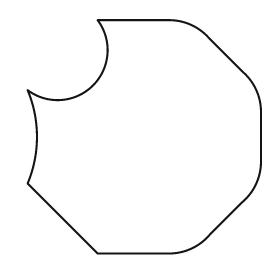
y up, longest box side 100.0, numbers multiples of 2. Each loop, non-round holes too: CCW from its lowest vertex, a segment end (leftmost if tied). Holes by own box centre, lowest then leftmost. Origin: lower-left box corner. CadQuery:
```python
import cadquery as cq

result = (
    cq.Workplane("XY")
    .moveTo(30.0, 0.0)
    .lineTo(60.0, 0.0)
    .threePointArc((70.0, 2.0), (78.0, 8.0))
    .lineTo(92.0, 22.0)
    .threePointArc((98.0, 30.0), (100.0, 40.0))
    .lineTo(100.0, 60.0)
    .threePointArc((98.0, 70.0), (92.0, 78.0))
    .lineTo(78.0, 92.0)
    .threePointArc((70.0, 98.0), (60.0, 100.0))
    .lineTo(30.0, 100.0)
    .threePointArc((28.0, 72.0), (0.0, 70.0))
    .threePointArc((4.0, 50.0), (0.0, 30.0))
    .close()
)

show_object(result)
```